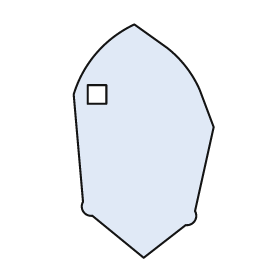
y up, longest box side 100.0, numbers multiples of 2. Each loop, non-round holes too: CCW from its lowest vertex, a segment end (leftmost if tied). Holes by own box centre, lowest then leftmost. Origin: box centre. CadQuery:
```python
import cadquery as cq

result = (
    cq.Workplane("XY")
    .moveTo(0.0, -50.0)
    .lineTo(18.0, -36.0)
    .threePointArc((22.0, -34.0), (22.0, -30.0))
    .lineTo(30.0, 6.0)
    .lineTo(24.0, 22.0)
    .threePointArc((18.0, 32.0), (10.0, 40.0))
    .lineTo(-4.0, 50.0)
    .threePointArc((-20.0, 38.0), (-30.0, 20.0))
    .lineTo(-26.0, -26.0)
    .threePointArc((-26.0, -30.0), (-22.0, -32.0))
    .close()
    .moveTo(-24.0, 16.0)
    .lineTo(-16.0, 16.0)
    .lineTo(-16.0, 24.0)
    .lineTo(-24.0, 24.0)
    .close()
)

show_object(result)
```